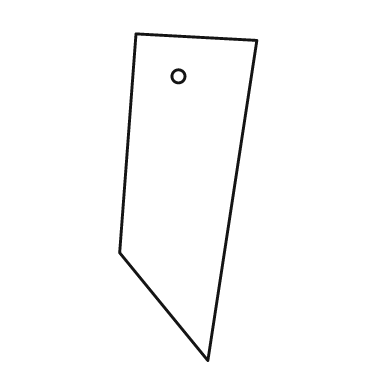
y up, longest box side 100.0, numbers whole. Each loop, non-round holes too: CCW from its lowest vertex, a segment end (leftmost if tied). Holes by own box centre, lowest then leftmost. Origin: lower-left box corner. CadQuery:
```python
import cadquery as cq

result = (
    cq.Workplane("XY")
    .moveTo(27.0, 0.0)
    .lineTo(42.0, 98.0)
    .lineTo(5.0, 100.0)
    .lineTo(0.0, 33.0)
    .close()
    .moveTo(18.0, 87.0)
    .circle(2.0)
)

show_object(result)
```